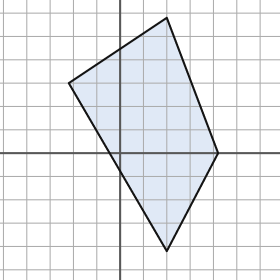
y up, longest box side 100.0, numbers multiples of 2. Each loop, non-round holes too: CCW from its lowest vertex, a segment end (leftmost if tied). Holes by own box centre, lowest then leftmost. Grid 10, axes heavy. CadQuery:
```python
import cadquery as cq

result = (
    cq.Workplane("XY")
    .moveTo(20.0, -42.0)
    .lineTo(42.0, 0.0)
    .lineTo(20.0, 58.0)
    .lineTo(-22.0, 30.0)
    .close()
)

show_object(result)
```